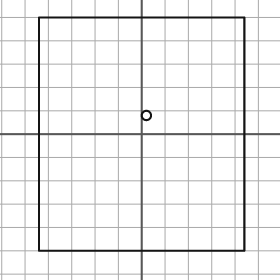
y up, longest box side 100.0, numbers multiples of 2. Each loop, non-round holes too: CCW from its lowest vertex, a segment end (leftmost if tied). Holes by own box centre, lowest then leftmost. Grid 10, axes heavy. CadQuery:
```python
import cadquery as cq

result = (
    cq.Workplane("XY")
    .moveTo(-44.0, -50.0)
    .lineTo(44.0, -50.0)
    .lineTo(44.0, 50.0)
    .lineTo(-44.0, 50.0)
    .close()
    .moveTo(2.0, 8.0)
    .circle(2.0)
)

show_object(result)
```